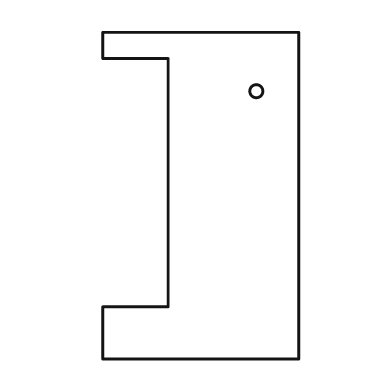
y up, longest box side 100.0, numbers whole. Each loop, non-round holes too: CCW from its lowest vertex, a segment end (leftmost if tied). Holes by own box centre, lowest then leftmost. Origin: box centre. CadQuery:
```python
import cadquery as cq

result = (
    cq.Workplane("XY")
    .moveTo(-30.0, -50.0)
    .lineTo(30.0, -50.0)
    .lineTo(30.0, 50.0)
    .lineTo(-30.0, 50.0)
    .lineTo(-30.0, 42.0)
    .lineTo(-10.0, 42.0)
    .lineTo(-10.0, -34.0)
    .lineTo(-30.0, -34.0)
    .close()
    .moveTo(17.0, 32.0)
    .circle(2.0)
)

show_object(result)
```